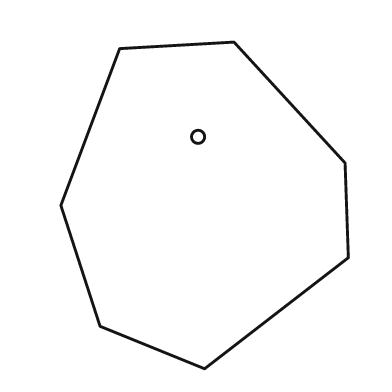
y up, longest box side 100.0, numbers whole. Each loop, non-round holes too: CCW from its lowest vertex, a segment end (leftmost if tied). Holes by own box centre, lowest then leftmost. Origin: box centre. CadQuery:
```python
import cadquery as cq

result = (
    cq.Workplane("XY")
    .moveTo(0.0, -50.0)
    .lineTo(44.0, -16.0)
    .lineTo(43.0, 13.0)
    .lineTo(9.0, 50.0)
    .lineTo(-26.0, 48.0)
    .lineTo(-44.0, 0.0)
    .lineTo(-32.0, -37.0)
    .close()
    .moveTo(-2.0, 21.0)
    .circle(2.0)
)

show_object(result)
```